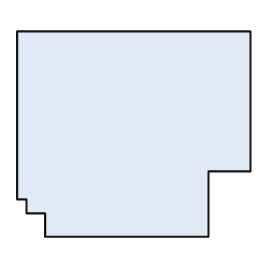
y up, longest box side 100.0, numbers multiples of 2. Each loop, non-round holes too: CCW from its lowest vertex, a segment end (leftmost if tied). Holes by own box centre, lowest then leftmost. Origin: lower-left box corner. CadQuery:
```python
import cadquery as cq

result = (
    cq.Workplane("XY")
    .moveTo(12.0, 0.0)
    .lineTo(82.0, 0.0)
    .lineTo(82.0, 28.0)
    .lineTo(100.0, 28.0)
    .lineTo(100.0, 88.0)
    .lineTo(0.0, 88.0)
    .lineTo(0.0, 16.0)
    .lineTo(4.0, 16.0)
    .lineTo(4.0, 10.0)
    .lineTo(12.0, 10.0)
    .close()
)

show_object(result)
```